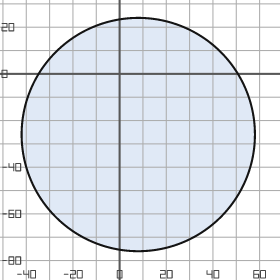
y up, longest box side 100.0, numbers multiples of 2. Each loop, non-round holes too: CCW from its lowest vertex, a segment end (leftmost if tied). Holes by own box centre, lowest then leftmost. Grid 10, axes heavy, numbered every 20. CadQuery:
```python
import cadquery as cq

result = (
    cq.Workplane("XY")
    .moveTo(8.0, -26.0)
    .circle(50.0)
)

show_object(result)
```